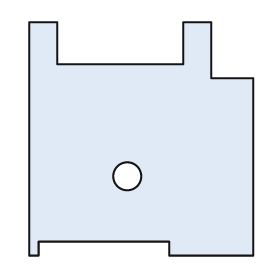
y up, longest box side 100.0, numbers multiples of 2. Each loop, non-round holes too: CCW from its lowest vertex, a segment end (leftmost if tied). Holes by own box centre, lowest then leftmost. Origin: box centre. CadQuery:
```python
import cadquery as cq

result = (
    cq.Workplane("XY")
    .moveTo(-48.0, -50.0)
    .lineTo(-44.0, -50.0)
    .lineTo(-44.0, -44.0)
    .lineTo(12.0, -44.0)
    .lineTo(12.0, -50.0)
    .lineTo(48.0, -50.0)
    .lineTo(48.0, 26.0)
    .lineTo(30.0, 26.0)
    .lineTo(30.0, 50.0)
    .lineTo(18.0, 50.0)
    .lineTo(18.0, 32.0)
    .lineTo(-36.0, 32.0)
    .lineTo(-36.0, 50.0)
    .lineTo(-48.0, 50.0)
    .close()
    .moveTo(-6.0, -16.0)
    .circle(6.0)
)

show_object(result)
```